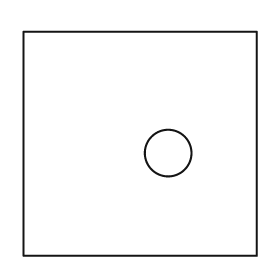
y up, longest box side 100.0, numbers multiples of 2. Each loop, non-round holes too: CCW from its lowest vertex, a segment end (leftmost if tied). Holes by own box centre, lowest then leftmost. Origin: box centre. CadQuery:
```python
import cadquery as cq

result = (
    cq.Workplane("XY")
    .moveTo(-50.0, -48.0)
    .lineTo(50.0, -48.0)
    .lineTo(50.0, 48.0)
    .lineTo(-50.0, 48.0)
    .close()
    .moveTo(12.0, -4.0)
    .circle(10.0)
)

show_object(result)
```